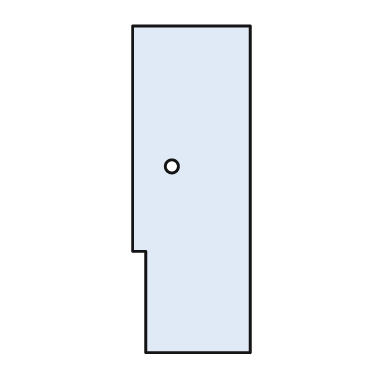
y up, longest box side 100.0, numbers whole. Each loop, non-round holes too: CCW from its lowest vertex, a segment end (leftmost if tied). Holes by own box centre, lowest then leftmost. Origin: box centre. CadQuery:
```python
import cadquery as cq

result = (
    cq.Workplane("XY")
    .moveTo(-14.0, -50.0)
    .lineTo(18.0, -50.0)
    .lineTo(18.0, 50.0)
    .lineTo(-18.0, 50.0)
    .lineTo(-18.0, -19.0)
    .lineTo(-14.0, -19.0)
    .close()
    .moveTo(-6.0, 7.0)
    .circle(2.0)
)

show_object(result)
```